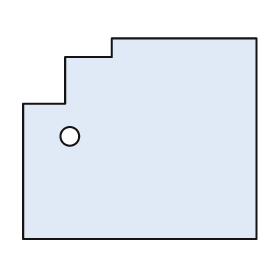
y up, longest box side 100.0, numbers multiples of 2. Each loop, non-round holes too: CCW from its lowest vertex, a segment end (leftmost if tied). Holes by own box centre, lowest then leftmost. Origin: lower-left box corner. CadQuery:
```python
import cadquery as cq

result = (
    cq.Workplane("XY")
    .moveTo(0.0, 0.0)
    .lineTo(100.0, 0.0)
    .lineTo(100.0, 86.0)
    .lineTo(38.0, 86.0)
    .lineTo(38.0, 78.0)
    .lineTo(18.0, 78.0)
    .lineTo(18.0, 58.0)
    .lineTo(0.0, 58.0)
    .close()
    .moveTo(20.0, 44.0)
    .circle(4.0)
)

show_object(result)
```